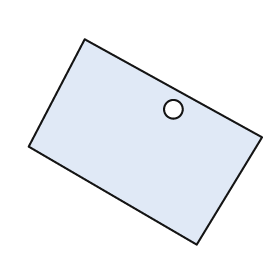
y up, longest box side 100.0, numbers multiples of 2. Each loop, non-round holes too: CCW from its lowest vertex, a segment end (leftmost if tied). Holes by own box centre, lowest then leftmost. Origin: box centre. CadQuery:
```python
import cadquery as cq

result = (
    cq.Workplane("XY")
    .moveTo(22.0, -44.0)
    .lineTo(50.0, 2.0)
    .lineTo(-26.0, 44.0)
    .lineTo(-50.0, -2.0)
    .close()
    .moveTo(12.0, 14.0)
    .circle(4.0)
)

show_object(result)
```